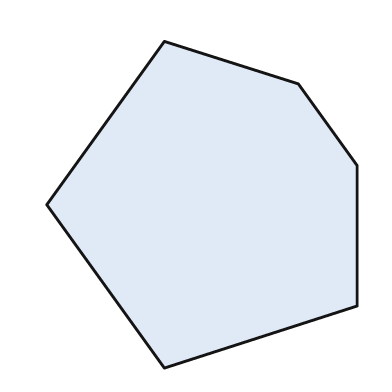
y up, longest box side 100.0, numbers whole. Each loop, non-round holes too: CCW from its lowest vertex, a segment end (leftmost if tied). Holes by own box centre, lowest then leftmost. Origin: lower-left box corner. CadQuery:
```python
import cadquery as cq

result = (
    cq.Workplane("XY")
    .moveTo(36.0, 0.0)
    .lineTo(95.0, 19.0)
    .lineTo(95.0, 62.0)
    .lineTo(77.0, 87.0)
    .lineTo(36.0, 100.0)
    .lineTo(0.0, 50.0)
    .close()
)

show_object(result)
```